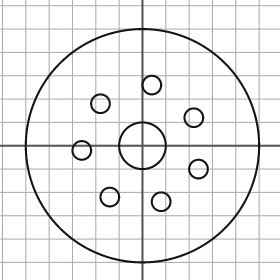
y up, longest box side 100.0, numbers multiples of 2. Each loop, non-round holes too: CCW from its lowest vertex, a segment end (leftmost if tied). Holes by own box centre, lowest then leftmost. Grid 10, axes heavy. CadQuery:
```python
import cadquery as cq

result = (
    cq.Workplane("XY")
    .moveTo(0.0, 0.0)
    .circle(50.0)
    .moveTo(8.0, -24.0)
    .circle(4.0)
    .moveTo(-14.0, -22.0)
    .circle(4.0)
    .moveTo(24.0, -10.0)
    .circle(4.0)
    .moveTo(-26.0, -2.0)
    .circle(4.0)
    .moveTo(0.0, 0.0)
    .circle(10.0)
    .moveTo(22.0, 12.0)
    .circle(4.0)
    .moveTo(-18.0, 18.0)
    .circle(4.0)
    .moveTo(4.0, 26.0)
    .circle(4.0)
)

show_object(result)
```